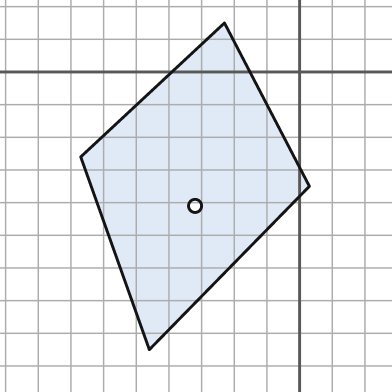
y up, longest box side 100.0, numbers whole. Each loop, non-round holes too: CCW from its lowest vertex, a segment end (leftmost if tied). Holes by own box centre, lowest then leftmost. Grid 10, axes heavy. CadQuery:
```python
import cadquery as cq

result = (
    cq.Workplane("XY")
    .moveTo(-46.0, -85.0)
    .lineTo(3.0, -35.0)
    .lineTo(-23.0, 15.0)
    .lineTo(-67.0, -26.0)
    .close()
    .moveTo(-32.0, -41.0)
    .circle(2.0)
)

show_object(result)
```